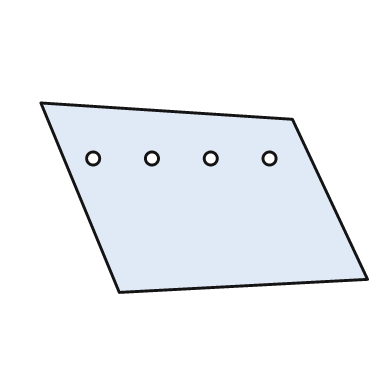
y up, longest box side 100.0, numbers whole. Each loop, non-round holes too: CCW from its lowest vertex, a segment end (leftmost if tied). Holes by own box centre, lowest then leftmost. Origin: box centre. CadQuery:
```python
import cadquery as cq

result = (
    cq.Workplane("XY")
    .moveTo(-26.0, -29.0)
    .lineTo(50.0, -25.0)
    .lineTo(27.0, 24.0)
    .lineTo(-50.0, 29.0)
    .close()
    .moveTo(-34.0, 12.0)
    .circle(2.0)
    .moveTo(-16.0, 12.0)
    .circle(2.0)
    .moveTo(2.0, 12.0)
    .circle(2.0)
    .moveTo(20.0, 12.0)
    .circle(2.0)
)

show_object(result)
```